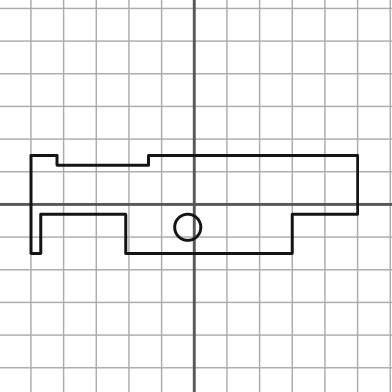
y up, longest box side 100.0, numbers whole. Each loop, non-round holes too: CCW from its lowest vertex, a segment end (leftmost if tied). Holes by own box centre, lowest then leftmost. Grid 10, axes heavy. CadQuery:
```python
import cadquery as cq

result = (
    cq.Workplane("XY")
    .moveTo(-50.0, -15.0)
    .lineTo(-47.0, -15.0)
    .lineTo(-47.0, -3.0)
    .lineTo(-21.0, -3.0)
    .lineTo(-21.0, -15.0)
    .lineTo(30.0, -15.0)
    .lineTo(30.0, -3.0)
    .lineTo(50.0, -3.0)
    .lineTo(50.0, 15.0)
    .lineTo(-14.0, 15.0)
    .lineTo(-14.0, 12.0)
    .lineTo(-42.0, 12.0)
    .lineTo(-42.0, 15.0)
    .lineTo(-50.0, 15.0)
    .close()
    .moveTo(-2.0, -7.0)
    .circle(4.0)
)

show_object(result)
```